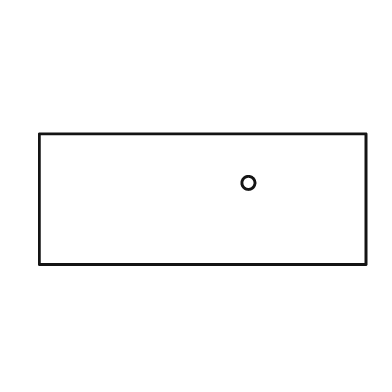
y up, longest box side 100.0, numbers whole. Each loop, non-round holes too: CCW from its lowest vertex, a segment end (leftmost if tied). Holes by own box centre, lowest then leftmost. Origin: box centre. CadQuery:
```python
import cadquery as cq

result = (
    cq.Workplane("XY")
    .moveTo(-50.0, -20.0)
    .lineTo(50.0, -20.0)
    .lineTo(50.0, 20.0)
    .lineTo(-50.0, 20.0)
    .close()
    .moveTo(14.0, 5.0)
    .circle(2.0)
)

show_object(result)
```